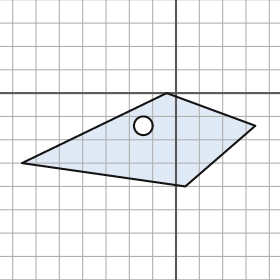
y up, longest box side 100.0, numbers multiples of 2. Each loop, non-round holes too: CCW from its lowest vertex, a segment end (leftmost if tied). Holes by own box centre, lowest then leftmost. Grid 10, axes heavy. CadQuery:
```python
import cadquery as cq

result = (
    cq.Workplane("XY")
    .moveTo(4.0, -40.0)
    .lineTo(34.0, -14.0)
    .lineTo(-4.0, 0.0)
    .lineTo(-66.0, -30.0)
    .close()
    .moveTo(-14.0, -14.0)
    .circle(4.0)
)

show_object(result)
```